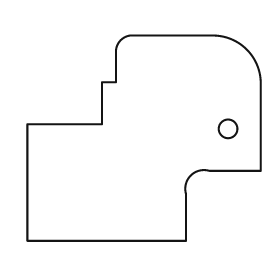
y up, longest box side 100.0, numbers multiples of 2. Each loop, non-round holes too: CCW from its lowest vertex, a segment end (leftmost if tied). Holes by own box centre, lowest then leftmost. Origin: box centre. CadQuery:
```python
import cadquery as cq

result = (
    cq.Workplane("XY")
    .moveTo(-50.0, -44.0)
    .lineTo(18.0, -44.0)
    .lineTo(18.0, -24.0)
    .threePointArc((20.0, -16.0), (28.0, -14.0))
    .lineTo(50.0, -14.0)
    .lineTo(50.0, 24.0)
    .threePointArc((44.0, 38.0), (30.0, 44.0))
    .lineTo(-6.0, 44.0)
    .threePointArc((-10.0, 42.0), (-12.0, 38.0))
    .lineTo(-12.0, 24.0)
    .lineTo(-18.0, 24.0)
    .lineTo(-18.0, 6.0)
    .lineTo(-50.0, 6.0)
    .close()
    .moveTo(36.0, 4.0)
    .circle(4.0)
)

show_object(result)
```